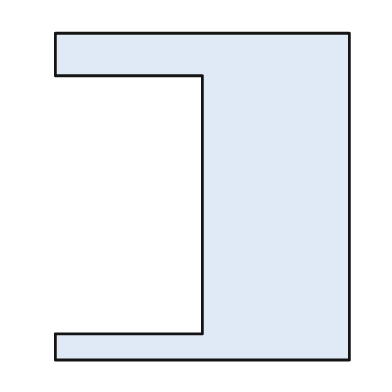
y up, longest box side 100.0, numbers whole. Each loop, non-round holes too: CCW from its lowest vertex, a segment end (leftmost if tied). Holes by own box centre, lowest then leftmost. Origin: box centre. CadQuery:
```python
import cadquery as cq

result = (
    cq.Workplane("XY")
    .moveTo(-45.0, -50.0)
    .lineTo(45.0, -50.0)
    .lineTo(45.0, 50.0)
    .lineTo(-45.0, 50.0)
    .lineTo(-45.0, 37.0)
    .lineTo(0.0, 37.0)
    .lineTo(0.0, -42.0)
    .lineTo(-45.0, -42.0)
    .close()
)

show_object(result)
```